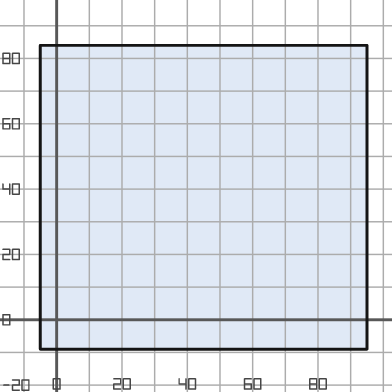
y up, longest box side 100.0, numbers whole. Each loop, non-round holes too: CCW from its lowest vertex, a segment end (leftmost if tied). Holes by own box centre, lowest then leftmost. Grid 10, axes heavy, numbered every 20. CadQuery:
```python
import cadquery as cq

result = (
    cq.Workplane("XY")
    .moveTo(-5.0, -9.0)
    .lineTo(95.0, -9.0)
    .lineTo(95.0, 84.0)
    .lineTo(-5.0, 84.0)
    .close()
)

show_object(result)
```